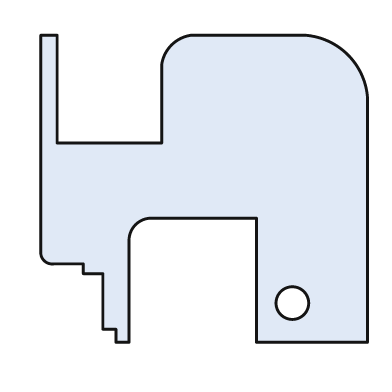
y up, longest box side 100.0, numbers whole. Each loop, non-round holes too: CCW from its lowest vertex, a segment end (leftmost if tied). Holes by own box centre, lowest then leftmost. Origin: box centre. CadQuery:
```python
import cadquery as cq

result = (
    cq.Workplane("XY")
    .moveTo(-27.0, -47.0)
    .lineTo(-23.0, -47.0)
    .lineTo(-23.0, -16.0)
    .threePointArc((-21.0, -11.0), (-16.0, -9.0))
    .lineTo(16.0, -9.0)
    .lineTo(16.0, -47.0)
    .lineTo(50.0, -47.0)
    .lineTo(50.0, 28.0)
    .threePointArc((44.0, 41.0), (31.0, 47.0))
    .lineTo(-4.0, 47.0)
    .threePointArc((-10.0, 44.0), (-13.0, 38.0))
    .lineTo(-13.0, 14.0)
    .lineTo(-45.0, 14.0)
    .lineTo(-45.0, 47.0)
    .lineTo(-50.0, 47.0)
    .lineTo(-50.0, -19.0)
    .threePointArc((-49.0, -22.0), (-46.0, -23.0))
    .lineTo(-37.0, -23.0)
    .lineTo(-37.0, -26.0)
    .lineTo(-31.0, -26.0)
    .lineTo(-31.0, -43.0)
    .lineTo(-27.0, -43.0)
    .close()
    .moveTo(27.0, -35.0)
    .circle(5.0)
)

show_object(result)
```